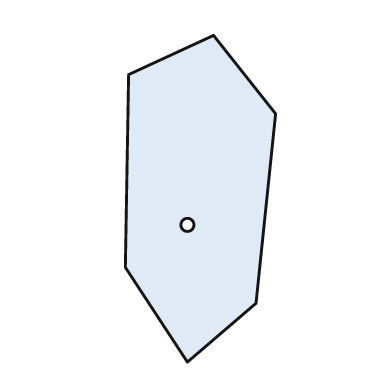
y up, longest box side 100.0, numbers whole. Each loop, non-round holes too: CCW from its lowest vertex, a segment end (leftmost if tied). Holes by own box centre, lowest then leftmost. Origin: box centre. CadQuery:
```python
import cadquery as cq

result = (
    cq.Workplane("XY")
    .moveTo(-4.0, -50.0)
    .lineTo(17.0, -32.0)
    .lineTo(23.0, 26.0)
    .lineTo(4.0, 50.0)
    .lineTo(-22.0, 38.0)
    .lineTo(-23.0, -21.0)
    .close()
    .moveTo(-4.0, -8.0)
    .circle(2.0)
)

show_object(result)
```